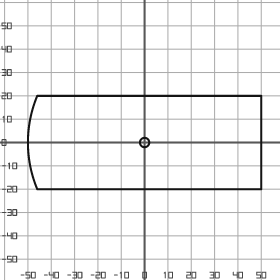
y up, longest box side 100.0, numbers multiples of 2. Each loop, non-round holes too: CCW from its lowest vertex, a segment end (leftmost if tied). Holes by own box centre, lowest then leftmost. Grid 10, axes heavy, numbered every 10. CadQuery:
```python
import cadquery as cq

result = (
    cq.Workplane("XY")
    .moveTo(-46.0, -20.0)
    .lineTo(50.0, -20.0)
    .lineTo(50.0, 20.0)
    .lineTo(-46.0, 20.0)
    .threePointArc((-50.0, 0.0), (-46.0, -20.0))
    .close()
    .moveTo(0.0, 0.0)
    .circle(2.0)
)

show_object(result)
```